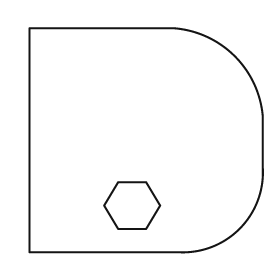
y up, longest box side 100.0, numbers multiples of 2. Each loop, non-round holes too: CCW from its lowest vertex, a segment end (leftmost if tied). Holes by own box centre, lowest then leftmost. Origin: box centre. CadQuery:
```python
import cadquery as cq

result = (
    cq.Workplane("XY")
    .moveTo(-50.0, -48.0)
    .lineTo(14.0, -48.0)
    .threePointArc((40.0, -38.0), (50.0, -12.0))
    .lineTo(50.0, 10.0)
    .threePointArc((38.0, 36.0), (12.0, 48.0))
    .lineTo(-50.0, 48.0)
    .close()
    .moveTo(-12.0, -38.0)
    .lineTo(0.0, -38.0)
    .lineTo(6.0, -28.0)
    .lineTo(0.0, -18.0)
    .lineTo(-12.0, -18.0)
    .lineTo(-18.0, -28.0)
    .close()
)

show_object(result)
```